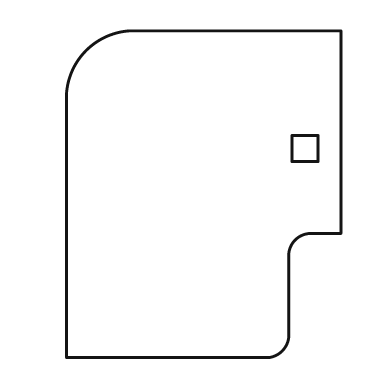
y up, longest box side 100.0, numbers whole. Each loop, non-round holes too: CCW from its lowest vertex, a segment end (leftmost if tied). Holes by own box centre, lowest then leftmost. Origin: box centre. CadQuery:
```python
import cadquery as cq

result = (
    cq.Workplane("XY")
    .moveTo(-42.0, -50.0)
    .lineTo(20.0, -50.0)
    .threePointArc((24.0, -48.0), (26.0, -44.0))
    .lineTo(26.0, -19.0)
    .threePointArc((28.0, -14.0), (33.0, -12.0))
    .lineTo(42.0, -12.0)
    .lineTo(42.0, 50.0)
    .lineTo(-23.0, 50.0)
    .threePointArc((-36.0, 44.0), (-42.0, 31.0))
    .close()
    .moveTo(27.0, 10.0)
    .lineTo(35.0, 10.0)
    .lineTo(35.0, 18.0)
    .lineTo(27.0, 18.0)
    .close()
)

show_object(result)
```